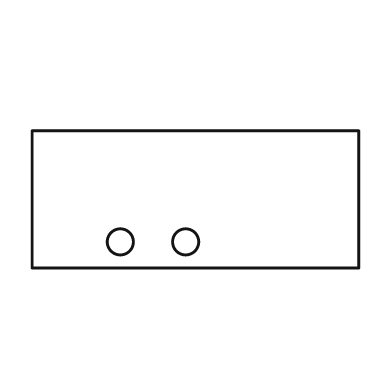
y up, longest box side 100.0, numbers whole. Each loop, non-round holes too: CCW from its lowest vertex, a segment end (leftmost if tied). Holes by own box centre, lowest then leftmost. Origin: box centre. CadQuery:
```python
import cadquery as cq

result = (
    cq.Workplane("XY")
    .moveTo(-50.0, -21.0)
    .lineTo(50.0, -21.0)
    .lineTo(50.0, 21.0)
    .lineTo(-50.0, 21.0)
    .close()
    .moveTo(-23.0, -13.0)
    .circle(4.0)
    .moveTo(-3.0, -13.0)
    .circle(4.0)
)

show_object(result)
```